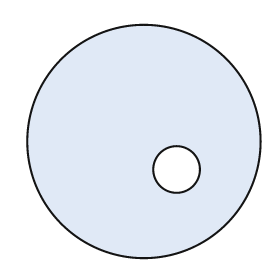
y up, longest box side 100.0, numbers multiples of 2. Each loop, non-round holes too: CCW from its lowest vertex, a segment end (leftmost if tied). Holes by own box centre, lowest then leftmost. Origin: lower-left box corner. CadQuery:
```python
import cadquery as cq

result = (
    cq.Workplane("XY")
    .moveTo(50.0, 50.0)
    .circle(50.0)
    .moveTo(64.0, 38.0)
    .circle(10.0)
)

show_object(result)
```